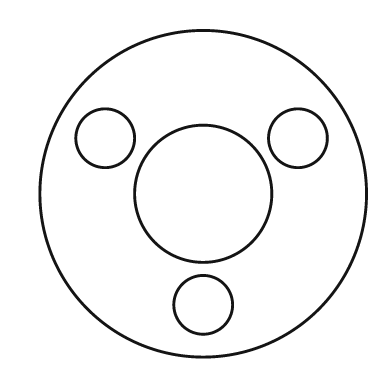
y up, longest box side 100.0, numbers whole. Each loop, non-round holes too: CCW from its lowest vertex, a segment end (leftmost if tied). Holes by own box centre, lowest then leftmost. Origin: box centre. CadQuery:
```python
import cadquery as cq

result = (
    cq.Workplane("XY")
    .moveTo(0.0, 0.0)
    .circle(50.0)
    .moveTo(0.0, -34.0)
    .circle(9.0)
    .moveTo(0.0, 0.0)
    .circle(21.0)
    .moveTo(-30.0, 17.0)
    .circle(9.0)
    .moveTo(29.0, 17.0)
    .circle(9.0)
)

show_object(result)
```